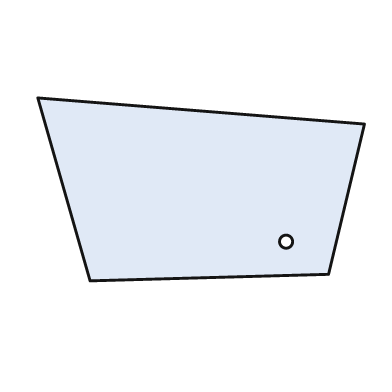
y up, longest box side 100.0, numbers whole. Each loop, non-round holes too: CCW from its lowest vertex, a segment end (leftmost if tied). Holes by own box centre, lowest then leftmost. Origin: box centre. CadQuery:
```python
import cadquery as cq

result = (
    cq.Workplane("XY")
    .moveTo(-34.0, -28.0)
    .lineTo(39.0, -26.0)
    .lineTo(50.0, 20.0)
    .lineTo(-50.0, 28.0)
    .close()
    .moveTo(26.0, -16.0)
    .circle(2.0)
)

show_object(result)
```